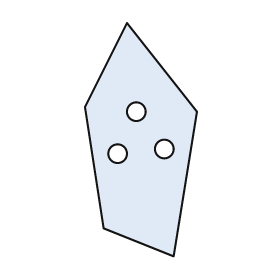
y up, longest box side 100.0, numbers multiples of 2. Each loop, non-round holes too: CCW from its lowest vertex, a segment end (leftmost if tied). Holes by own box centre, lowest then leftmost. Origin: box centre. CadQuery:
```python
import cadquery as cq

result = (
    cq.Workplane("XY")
    .moveTo(14.0, -50.0)
    .lineTo(24.0, 12.0)
    .lineTo(-6.0, 50.0)
    .lineTo(-24.0, 14.0)
    .lineTo(-16.0, -38.0)
    .close()
    .moveTo(-10.0, -6.0)
    .circle(4.0)
    .moveTo(10.0, -4.0)
    .circle(4.0)
    .moveTo(-2.0, 12.0)
    .circle(4.0)
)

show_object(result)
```